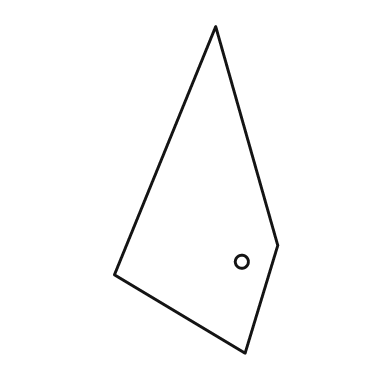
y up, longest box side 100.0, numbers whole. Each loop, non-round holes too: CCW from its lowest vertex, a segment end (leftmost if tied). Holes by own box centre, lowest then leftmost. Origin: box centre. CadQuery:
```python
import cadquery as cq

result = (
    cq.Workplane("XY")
    .moveTo(15.0, -50.0)
    .lineTo(25.0, -17.0)
    .lineTo(6.0, 50.0)
    .lineTo(-25.0, -26.0)
    .close()
    .moveTo(14.0, -22.0)
    .circle(2.0)
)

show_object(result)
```